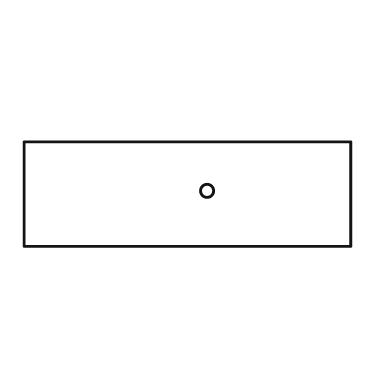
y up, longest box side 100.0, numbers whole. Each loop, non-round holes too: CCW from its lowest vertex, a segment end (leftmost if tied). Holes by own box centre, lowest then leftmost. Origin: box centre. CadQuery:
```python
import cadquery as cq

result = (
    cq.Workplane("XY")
    .moveTo(-50.0, -16.0)
    .lineTo(50.0, -16.0)
    .lineTo(50.0, 16.0)
    .lineTo(-50.0, 16.0)
    .close()
    .moveTo(6.0, 1.0)
    .circle(2.0)
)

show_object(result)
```